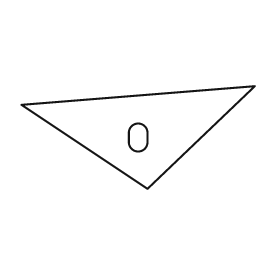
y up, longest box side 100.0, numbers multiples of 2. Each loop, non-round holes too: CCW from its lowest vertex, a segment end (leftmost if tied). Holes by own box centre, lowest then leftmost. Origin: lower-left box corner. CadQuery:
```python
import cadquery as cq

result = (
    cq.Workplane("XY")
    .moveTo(54.0, 0.0)
    .lineTo(100.0, 44.0)
    .lineTo(0.0, 36.0)
    .close()
    .moveTo(46.0, 20.0)
    .threePointArc((50.0, 16.0), (54.0, 20.0))
    .lineTo(54.0, 24.0)
    .threePointArc((50.0, 28.0), (46.0, 24.0))
    .close()
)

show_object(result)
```